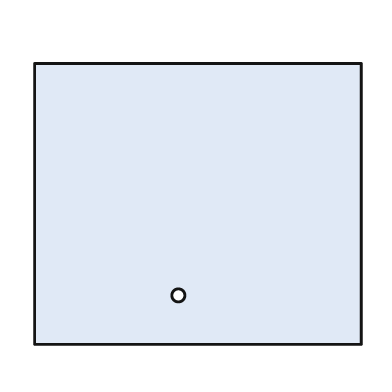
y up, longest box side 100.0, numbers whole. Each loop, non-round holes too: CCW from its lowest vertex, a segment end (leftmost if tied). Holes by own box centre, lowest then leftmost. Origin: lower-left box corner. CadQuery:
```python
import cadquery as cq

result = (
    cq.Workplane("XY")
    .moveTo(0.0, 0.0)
    .lineTo(100.0, 0.0)
    .lineTo(100.0, 86.0)
    .lineTo(0.0, 86.0)
    .close()
    .moveTo(44.0, 15.0)
    .circle(2.0)
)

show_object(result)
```